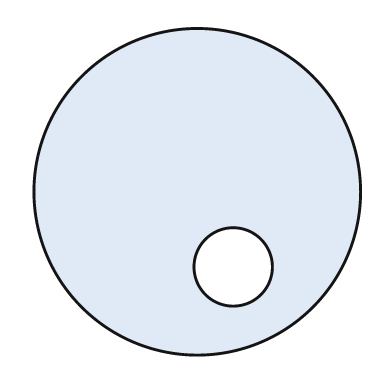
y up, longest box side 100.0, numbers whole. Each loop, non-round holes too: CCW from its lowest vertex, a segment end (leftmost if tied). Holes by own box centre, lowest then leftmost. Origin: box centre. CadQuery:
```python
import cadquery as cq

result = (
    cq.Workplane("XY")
    .moveTo(0.0, 0.0)
    .circle(50.0)
    .moveTo(11.0, -23.0)
    .circle(12.0)
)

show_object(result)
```